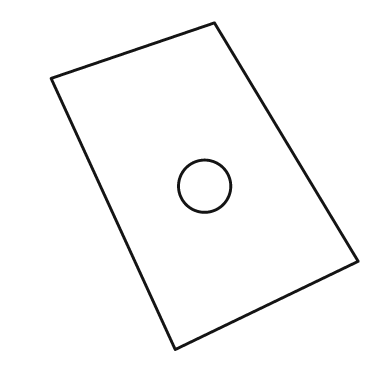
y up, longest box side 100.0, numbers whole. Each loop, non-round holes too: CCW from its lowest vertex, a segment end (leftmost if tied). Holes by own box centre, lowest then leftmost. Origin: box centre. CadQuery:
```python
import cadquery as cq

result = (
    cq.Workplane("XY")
    .moveTo(-9.0, -50.0)
    .lineTo(47.0, -23.0)
    .lineTo(3.0, 50.0)
    .lineTo(-47.0, 33.0)
    .close()
    .moveTo(0.0, 0.0)
    .circle(8.0)
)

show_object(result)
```